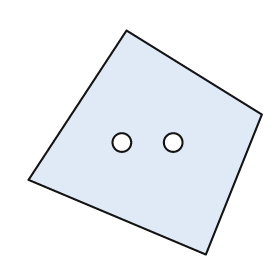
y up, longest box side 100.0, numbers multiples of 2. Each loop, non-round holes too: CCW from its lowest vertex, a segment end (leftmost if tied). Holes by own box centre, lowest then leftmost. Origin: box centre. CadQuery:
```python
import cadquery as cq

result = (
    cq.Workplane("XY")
    .moveTo(26.0, -48.0)
    .lineTo(50.0, 12.0)
    .lineTo(-8.0, 48.0)
    .lineTo(-50.0, -16.0)
    .close()
    .moveTo(-10.0, 0.0)
    .circle(4.0)
    .moveTo(12.0, 0.0)
    .circle(4.0)
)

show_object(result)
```